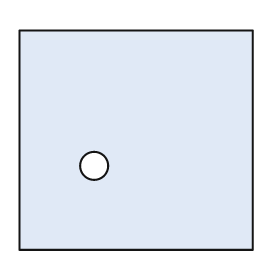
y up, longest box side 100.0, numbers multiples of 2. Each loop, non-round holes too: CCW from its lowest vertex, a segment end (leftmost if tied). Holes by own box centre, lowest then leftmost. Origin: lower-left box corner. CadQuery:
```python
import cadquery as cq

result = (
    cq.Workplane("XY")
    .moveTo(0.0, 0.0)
    .lineTo(100.0, 0.0)
    .lineTo(100.0, 94.0)
    .lineTo(0.0, 94.0)
    .close()
    .moveTo(32.0, 36.0)
    .circle(6.0)
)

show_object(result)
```